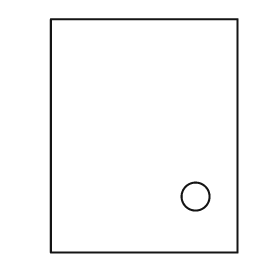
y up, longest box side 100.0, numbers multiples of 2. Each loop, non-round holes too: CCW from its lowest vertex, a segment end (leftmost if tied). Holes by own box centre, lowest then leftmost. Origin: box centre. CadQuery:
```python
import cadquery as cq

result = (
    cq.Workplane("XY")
    .moveTo(-40.0, -50.0)
    .lineTo(40.0, -50.0)
    .lineTo(40.0, 50.0)
    .lineTo(-40.0, 50.0)
    .close()
    .moveTo(22.0, -26.0)
    .circle(6.0)
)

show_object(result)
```